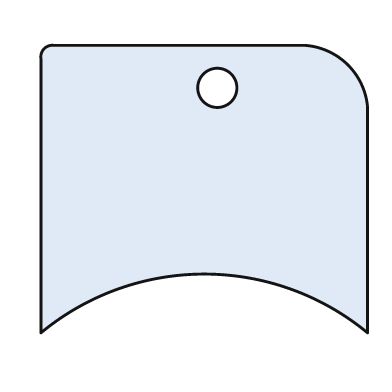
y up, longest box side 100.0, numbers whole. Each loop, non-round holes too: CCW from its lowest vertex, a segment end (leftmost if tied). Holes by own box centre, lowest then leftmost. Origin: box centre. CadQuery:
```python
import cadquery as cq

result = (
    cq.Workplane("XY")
    .moveTo(-50.0, -44.0)
    .threePointArc((0.0, -26.0), (50.0, -44.0))
    .lineTo(50.0, 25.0)
    .threePointArc((44.0, 38.0), (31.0, 44.0))
    .lineTo(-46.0, 44.0)
    .threePointArc((-49.0, 43.0), (-50.0, 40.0))
    .close()
    .moveTo(4.0, 31.0)
    .circle(6.0)
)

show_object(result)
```